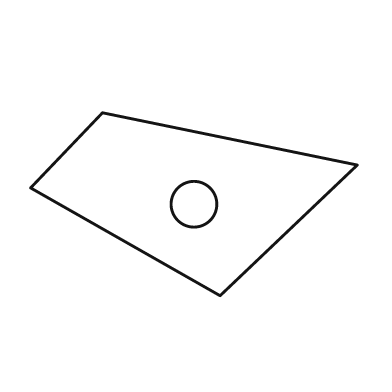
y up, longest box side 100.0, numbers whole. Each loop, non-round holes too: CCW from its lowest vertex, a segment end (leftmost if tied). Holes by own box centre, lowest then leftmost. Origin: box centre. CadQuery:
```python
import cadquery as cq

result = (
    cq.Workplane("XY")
    .moveTo(8.0, -28.0)
    .lineTo(50.0, 12.0)
    .lineTo(-28.0, 28.0)
    .lineTo(-50.0, 5.0)
    .close()
    .moveTo(0.0, 0.0)
    .circle(7.0)
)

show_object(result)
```